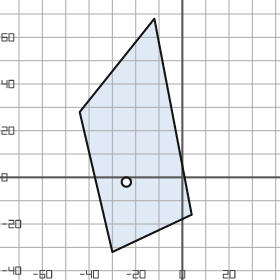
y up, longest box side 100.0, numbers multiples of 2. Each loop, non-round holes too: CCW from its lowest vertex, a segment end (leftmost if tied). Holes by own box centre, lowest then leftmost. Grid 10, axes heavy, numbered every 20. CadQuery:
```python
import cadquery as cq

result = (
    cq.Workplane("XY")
    .moveTo(-30.0, -32.0)
    .lineTo(4.0, -16.0)
    .lineTo(-12.0, 68.0)
    .lineTo(-44.0, 28.0)
    .close()
    .moveTo(-24.0, -2.0)
    .circle(2.0)
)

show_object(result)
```